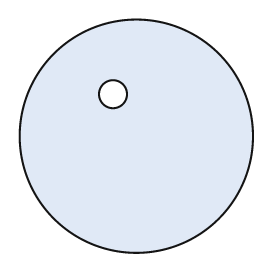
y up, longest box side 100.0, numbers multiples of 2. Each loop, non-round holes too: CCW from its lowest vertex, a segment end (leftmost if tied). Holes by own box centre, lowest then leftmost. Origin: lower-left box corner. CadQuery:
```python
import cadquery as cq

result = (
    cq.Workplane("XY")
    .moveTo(50.0, 50.0)
    .circle(50.0)
    .moveTo(40.0, 68.0)
    .circle(6.0)
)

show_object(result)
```